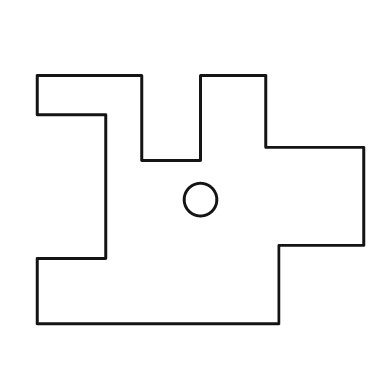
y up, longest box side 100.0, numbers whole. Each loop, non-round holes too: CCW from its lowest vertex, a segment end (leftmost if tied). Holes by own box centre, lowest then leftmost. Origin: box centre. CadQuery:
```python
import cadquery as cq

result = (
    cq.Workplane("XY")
    .moveTo(-50.0, -38.0)
    .lineTo(24.0, -38.0)
    .lineTo(24.0, -14.0)
    .lineTo(50.0, -14.0)
    .lineTo(50.0, 16.0)
    .lineTo(20.0, 16.0)
    .lineTo(20.0, 38.0)
    .lineTo(0.0, 38.0)
    .lineTo(0.0, 12.0)
    .lineTo(-18.0, 12.0)
    .lineTo(-18.0, 38.0)
    .lineTo(-50.0, 38.0)
    .lineTo(-50.0, 26.0)
    .lineTo(-29.0, 26.0)
    .lineTo(-29.0, -18.0)
    .lineTo(-50.0, -18.0)
    .close()
    .moveTo(0.0, 0.0)
    .circle(5.0)
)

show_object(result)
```